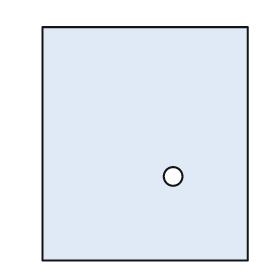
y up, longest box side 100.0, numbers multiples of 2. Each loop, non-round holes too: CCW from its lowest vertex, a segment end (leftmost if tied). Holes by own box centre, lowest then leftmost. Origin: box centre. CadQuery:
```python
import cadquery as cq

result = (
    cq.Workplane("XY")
    .moveTo(-44.0, -50.0)
    .lineTo(44.0, -50.0)
    .lineTo(44.0, 50.0)
    .lineTo(-44.0, 50.0)
    .close()
    .moveTo(12.0, -14.0)
    .circle(4.0)
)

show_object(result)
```